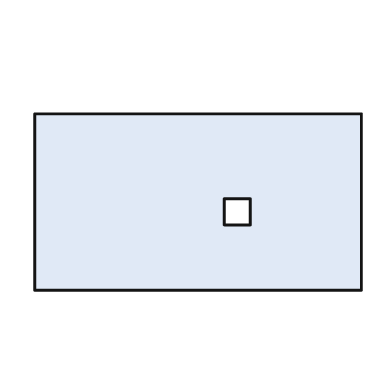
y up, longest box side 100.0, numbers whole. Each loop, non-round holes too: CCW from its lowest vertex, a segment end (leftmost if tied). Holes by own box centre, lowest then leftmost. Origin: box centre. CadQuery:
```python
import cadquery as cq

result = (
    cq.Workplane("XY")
    .moveTo(-50.0, -27.0)
    .lineTo(50.0, -27.0)
    .lineTo(50.0, 27.0)
    .lineTo(-50.0, 27.0)
    .close()
    .moveTo(8.0, -7.0)
    .lineTo(16.0, -7.0)
    .lineTo(16.0, 1.0)
    .lineTo(8.0, 1.0)
    .close()
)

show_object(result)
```